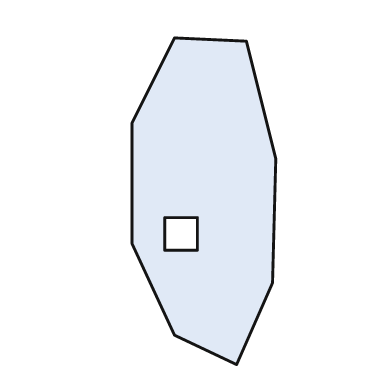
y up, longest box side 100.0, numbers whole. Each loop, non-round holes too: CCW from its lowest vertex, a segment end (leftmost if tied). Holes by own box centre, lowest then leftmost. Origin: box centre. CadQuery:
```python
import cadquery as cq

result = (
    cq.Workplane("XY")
    .moveTo(10.0, -50.0)
    .lineTo(21.0, -25.0)
    .lineTo(22.0, 13.0)
    .lineTo(13.0, 49.0)
    .lineTo(-9.0, 50.0)
    .lineTo(-22.0, 24.0)
    .lineTo(-22.0, -13.0)
    .lineTo(-9.0, -41.0)
    .close()
    .moveTo(-12.0, -15.0)
    .lineTo(-2.0, -15.0)
    .lineTo(-2.0, -5.0)
    .lineTo(-12.0, -5.0)
    .close()
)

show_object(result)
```